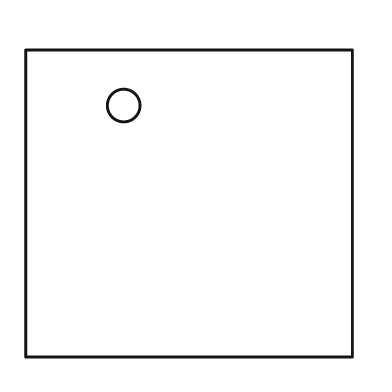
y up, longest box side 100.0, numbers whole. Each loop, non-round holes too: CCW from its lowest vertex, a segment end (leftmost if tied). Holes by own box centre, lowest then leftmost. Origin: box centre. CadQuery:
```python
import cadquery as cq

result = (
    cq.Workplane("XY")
    .moveTo(-50.0, -47.0)
    .lineTo(50.0, -47.0)
    .lineTo(50.0, 47.0)
    .lineTo(-50.0, 47.0)
    .close()
    .moveTo(-20.0, 30.0)
    .circle(5.0)
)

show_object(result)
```